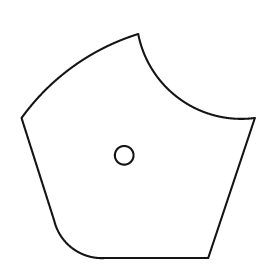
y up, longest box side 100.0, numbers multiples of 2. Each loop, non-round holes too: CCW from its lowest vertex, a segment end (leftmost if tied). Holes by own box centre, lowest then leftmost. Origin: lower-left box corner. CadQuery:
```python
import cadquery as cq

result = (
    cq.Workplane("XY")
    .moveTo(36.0, 0.0)
    .lineTo(80.0, 0.0)
    .lineTo(100.0, 60.0)
    .threePointArc((68.0, 68.0), (50.0, 96.0))
    .threePointArc((22.0, 82.0), (0.0, 60.0))
    .lineTo(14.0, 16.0)
    .threePointArc((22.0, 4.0), (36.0, 0.0))
    .close()
    .moveTo(44.0, 44.0)
    .circle(4.0)
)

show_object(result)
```